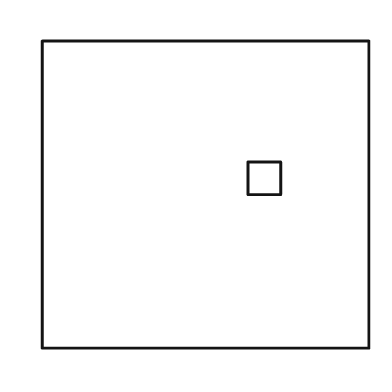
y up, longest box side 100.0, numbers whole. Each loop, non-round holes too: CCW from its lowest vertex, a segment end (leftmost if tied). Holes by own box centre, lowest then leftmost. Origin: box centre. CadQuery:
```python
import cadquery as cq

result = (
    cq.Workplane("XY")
    .moveTo(-50.0, -47.0)
    .lineTo(50.0, -47.0)
    .lineTo(50.0, 47.0)
    .lineTo(-50.0, 47.0)
    .close()
    .moveTo(13.0, 0.0)
    .lineTo(23.0, 0.0)
    .lineTo(23.0, 10.0)
    .lineTo(13.0, 10.0)
    .close()
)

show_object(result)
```